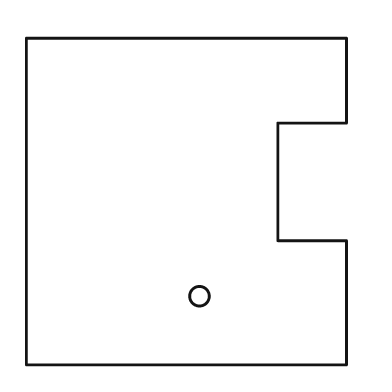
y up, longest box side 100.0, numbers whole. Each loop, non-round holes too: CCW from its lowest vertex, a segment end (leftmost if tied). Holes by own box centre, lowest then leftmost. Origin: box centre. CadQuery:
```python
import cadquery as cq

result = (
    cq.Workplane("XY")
    .moveTo(-49.0, -50.0)
    .lineTo(49.0, -50.0)
    .lineTo(49.0, -12.0)
    .lineTo(28.0, -12.0)
    .lineTo(28.0, 24.0)
    .lineTo(49.0, 24.0)
    .lineTo(49.0, 50.0)
    .lineTo(-49.0, 50.0)
    .close()
    .moveTo(4.0, -29.0)
    .circle(3.0)
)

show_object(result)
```